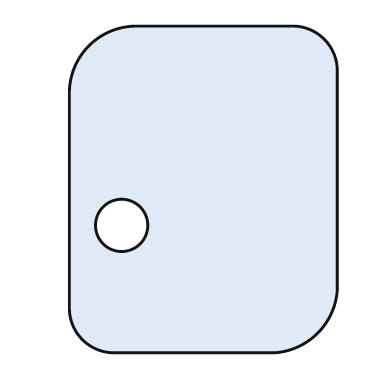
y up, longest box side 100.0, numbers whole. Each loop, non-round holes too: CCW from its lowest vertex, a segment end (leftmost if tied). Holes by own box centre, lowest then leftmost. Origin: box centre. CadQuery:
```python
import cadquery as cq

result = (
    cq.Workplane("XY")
    .moveTo(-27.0, -50.0)
    .lineTo(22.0, -50.0)
    .threePointArc((35.0, -44.0), (41.0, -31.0))
    .lineTo(41.0, 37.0)
    .threePointArc((37.0, 46.0), (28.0, 50.0))
    .lineTo(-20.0, 50.0)
    .threePointArc((-35.0, 44.0), (-41.0, 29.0))
    .lineTo(-41.0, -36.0)
    .threePointArc((-37.0, -46.0), (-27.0, -50.0))
    .close()
    .moveTo(-25.0, -11.0)
    .circle(8.0)
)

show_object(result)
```